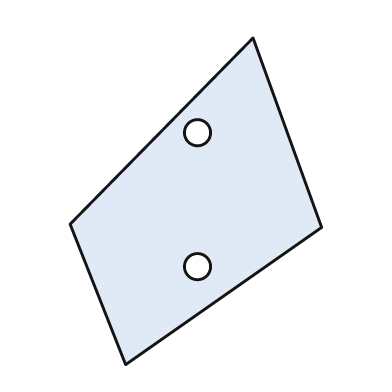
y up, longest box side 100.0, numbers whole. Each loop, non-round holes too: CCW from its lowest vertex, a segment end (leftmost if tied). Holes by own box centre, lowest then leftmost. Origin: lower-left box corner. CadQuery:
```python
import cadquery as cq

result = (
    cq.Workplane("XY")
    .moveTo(17.0, 0.0)
    .lineTo(77.0, 42.0)
    .lineTo(56.0, 100.0)
    .lineTo(0.0, 43.0)
    .close()
    .moveTo(39.0, 30.0)
    .circle(4.0)
    .moveTo(39.0, 71.0)
    .circle(4.0)
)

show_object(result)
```